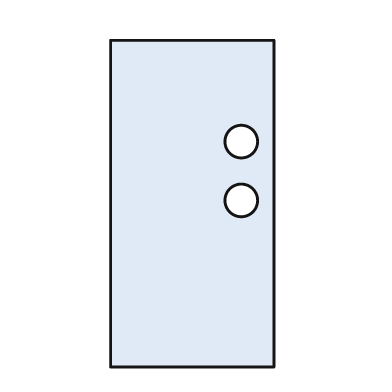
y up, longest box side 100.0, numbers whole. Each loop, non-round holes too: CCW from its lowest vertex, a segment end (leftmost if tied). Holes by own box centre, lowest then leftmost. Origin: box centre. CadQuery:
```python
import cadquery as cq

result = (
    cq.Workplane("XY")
    .moveTo(-25.0, -50.0)
    .lineTo(25.0, -50.0)
    .lineTo(25.0, 50.0)
    .lineTo(-25.0, 50.0)
    .close()
    .moveTo(15.0, 1.0)
    .circle(5.0)
    .moveTo(15.0, 19.0)
    .circle(5.0)
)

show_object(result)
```